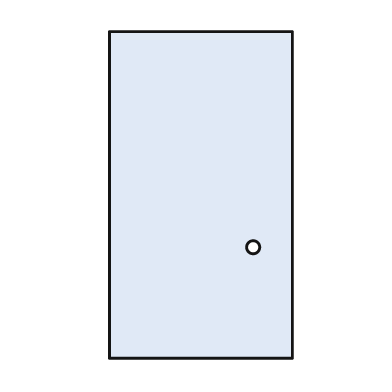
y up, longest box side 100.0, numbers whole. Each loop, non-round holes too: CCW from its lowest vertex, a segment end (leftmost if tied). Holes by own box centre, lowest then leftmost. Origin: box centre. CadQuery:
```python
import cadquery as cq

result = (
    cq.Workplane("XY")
    .moveTo(-28.0, -50.0)
    .lineTo(28.0, -50.0)
    .lineTo(28.0, 50.0)
    .lineTo(-28.0, 50.0)
    .close()
    .moveTo(16.0, -16.0)
    .circle(2.0)
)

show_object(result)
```